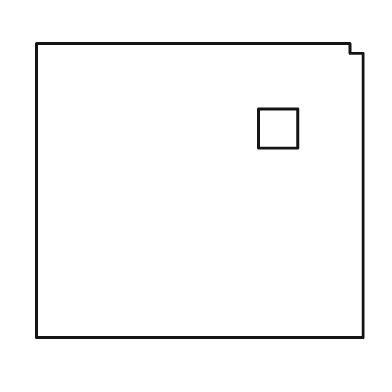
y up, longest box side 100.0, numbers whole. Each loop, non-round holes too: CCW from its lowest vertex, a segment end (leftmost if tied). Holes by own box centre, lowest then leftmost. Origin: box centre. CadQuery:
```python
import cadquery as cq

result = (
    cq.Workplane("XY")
    .moveTo(-50.0, -45.0)
    .lineTo(50.0, -45.0)
    .lineTo(50.0, 42.0)
    .lineTo(46.0, 42.0)
    .lineTo(46.0, 45.0)
    .lineTo(-50.0, 45.0)
    .close()
    .moveTo(18.0, 13.0)
    .lineTo(30.0, 13.0)
    .lineTo(30.0, 25.0)
    .lineTo(18.0, 25.0)
    .close()
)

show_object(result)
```